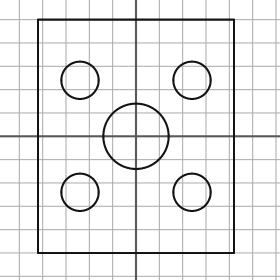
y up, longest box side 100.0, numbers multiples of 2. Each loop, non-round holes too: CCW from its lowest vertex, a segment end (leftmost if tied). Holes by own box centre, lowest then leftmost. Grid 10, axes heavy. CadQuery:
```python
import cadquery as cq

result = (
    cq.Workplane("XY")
    .moveTo(-42.0, -50.0)
    .lineTo(42.0, -50.0)
    .lineTo(42.0, 50.0)
    .lineTo(-42.0, 50.0)
    .close()
    .moveTo(-24.0, -24.0)
    .circle(8.0)
    .moveTo(24.0, -24.0)
    .circle(8.0)
    .moveTo(0.0, 0.0)
    .circle(14.0)
    .moveTo(-24.0, 24.0)
    .circle(8.0)
    .moveTo(24.0, 24.0)
    .circle(8.0)
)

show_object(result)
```